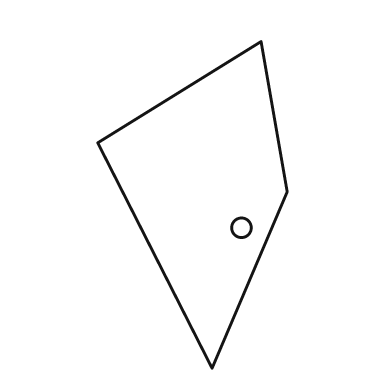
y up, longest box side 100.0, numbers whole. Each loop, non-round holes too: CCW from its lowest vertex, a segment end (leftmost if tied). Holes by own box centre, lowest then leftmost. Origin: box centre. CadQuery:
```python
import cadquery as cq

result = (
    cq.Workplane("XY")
    .moveTo(6.0, -50.0)
    .lineTo(29.0, 4.0)
    .lineTo(21.0, 50.0)
    .lineTo(-29.0, 19.0)
    .close()
    .moveTo(15.0, -7.0)
    .circle(3.0)
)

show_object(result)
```